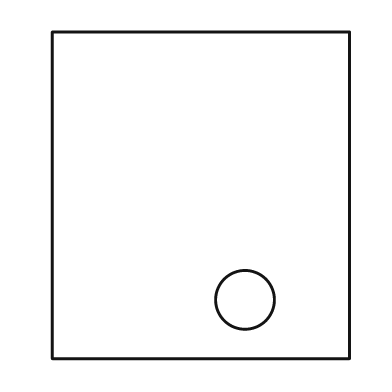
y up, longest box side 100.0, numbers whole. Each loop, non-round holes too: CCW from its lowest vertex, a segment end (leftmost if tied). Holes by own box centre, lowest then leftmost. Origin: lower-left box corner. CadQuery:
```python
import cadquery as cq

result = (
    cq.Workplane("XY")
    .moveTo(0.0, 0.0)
    .lineTo(91.0, 0.0)
    .lineTo(91.0, 100.0)
    .lineTo(0.0, 100.0)
    .close()
    .moveTo(59.0, 18.0)
    .circle(9.0)
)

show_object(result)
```